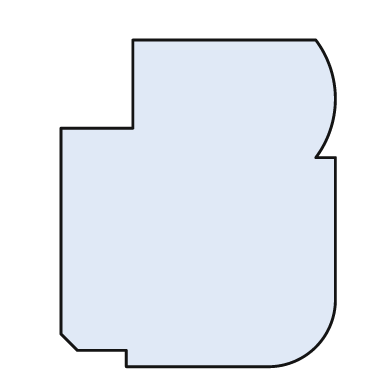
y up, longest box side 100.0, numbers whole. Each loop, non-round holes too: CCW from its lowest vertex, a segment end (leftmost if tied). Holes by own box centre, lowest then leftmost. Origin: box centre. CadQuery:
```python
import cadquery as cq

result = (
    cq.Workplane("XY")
    .moveTo(-22.0, -50.0)
    .lineTo(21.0, -50.0)
    .threePointArc((36.0, -44.0), (42.0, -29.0))
    .lineTo(42.0, 14.0)
    .lineTo(36.0, 14.0)
    .threePointArc((42.0, 32.0), (36.0, 50.0))
    .lineTo(-20.0, 50.0)
    .lineTo(-20.0, 23.0)
    .lineTo(-42.0, 23.0)
    .lineTo(-42.0, -40.0)
    .lineTo(-37.0, -45.0)
    .lineTo(-22.0, -45.0)
    .close()
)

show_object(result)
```